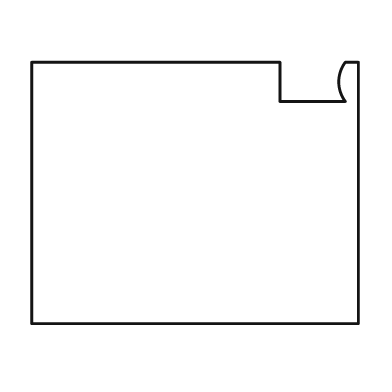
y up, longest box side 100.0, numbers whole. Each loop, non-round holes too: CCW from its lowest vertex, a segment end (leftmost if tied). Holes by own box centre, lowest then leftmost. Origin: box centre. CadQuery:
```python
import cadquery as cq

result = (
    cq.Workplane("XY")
    .moveTo(-50.0, -40.0)
    .lineTo(50.0, -40.0)
    .lineTo(50.0, 40.0)
    .lineTo(46.0, 40.0)
    .threePointArc((44.0, 34.0), (46.0, 28.0))
    .lineTo(26.0, 28.0)
    .lineTo(26.0, 40.0)
    .lineTo(-50.0, 40.0)
    .close()
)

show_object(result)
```